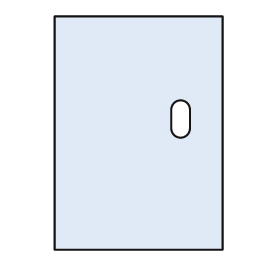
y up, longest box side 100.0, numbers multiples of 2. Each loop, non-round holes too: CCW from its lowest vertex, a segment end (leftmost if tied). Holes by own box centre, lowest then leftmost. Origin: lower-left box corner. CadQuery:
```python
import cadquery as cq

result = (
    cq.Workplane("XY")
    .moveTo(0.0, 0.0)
    .lineTo(72.0, 0.0)
    .lineTo(72.0, 100.0)
    .lineTo(0.0, 100.0)
    .close()
    .moveTo(50.0, 52.0)
    .threePointArc((54.0, 48.0), (58.0, 52.0))
    .lineTo(58.0, 60.0)
    .threePointArc((54.0, 64.0), (50.0, 60.0))
    .close()
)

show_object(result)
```